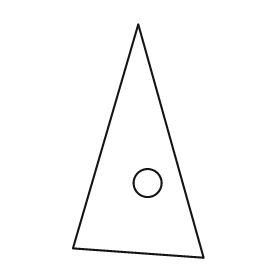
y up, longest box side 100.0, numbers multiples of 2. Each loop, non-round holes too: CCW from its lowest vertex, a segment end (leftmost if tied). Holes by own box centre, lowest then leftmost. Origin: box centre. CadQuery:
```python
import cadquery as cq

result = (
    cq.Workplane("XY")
    .moveTo(28.0, -50.0)
    .lineTo(0.0, 50.0)
    .lineTo(-28.0, -46.0)
    .close()
    .moveTo(4.0, -18.0)
    .circle(6.0)
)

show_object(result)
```